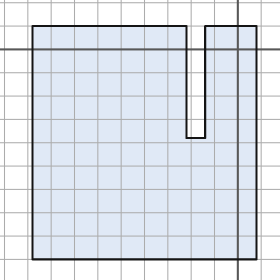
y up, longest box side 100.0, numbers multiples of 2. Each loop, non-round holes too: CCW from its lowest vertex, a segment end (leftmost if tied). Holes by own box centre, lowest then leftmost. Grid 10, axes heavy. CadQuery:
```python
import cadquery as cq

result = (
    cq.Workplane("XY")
    .moveTo(-88.0, -90.0)
    .lineTo(8.0, -90.0)
    .lineTo(8.0, 10.0)
    .lineTo(-14.0, 10.0)
    .lineTo(-14.0, -38.0)
    .lineTo(-22.0, -38.0)
    .lineTo(-22.0, 10.0)
    .lineTo(-88.0, 10.0)
    .close()
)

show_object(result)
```